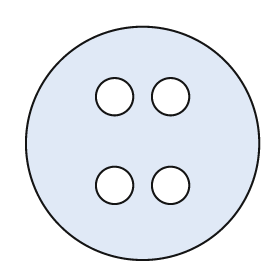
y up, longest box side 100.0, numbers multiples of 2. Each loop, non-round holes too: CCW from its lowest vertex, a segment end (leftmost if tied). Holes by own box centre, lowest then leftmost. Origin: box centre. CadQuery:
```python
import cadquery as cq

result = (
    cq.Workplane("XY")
    .moveTo(0.0, 0.0)
    .circle(50.0)
    .moveTo(-12.0, -18.0)
    .circle(8.0)
    .moveTo(12.0, -18.0)
    .circle(8.0)
    .moveTo(-12.0, 20.0)
    .circle(8.0)
    .moveTo(12.0, 20.0)
    .circle(8.0)
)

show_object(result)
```